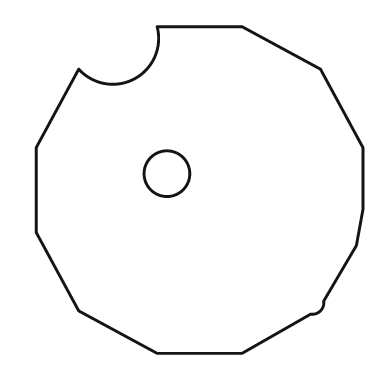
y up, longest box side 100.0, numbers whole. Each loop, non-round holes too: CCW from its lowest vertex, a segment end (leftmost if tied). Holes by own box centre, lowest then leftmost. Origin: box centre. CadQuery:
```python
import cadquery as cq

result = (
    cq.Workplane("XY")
    .moveTo(-13.0, -50.0)
    .lineTo(13.0, -50.0)
    .lineTo(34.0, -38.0)
    .threePointArc((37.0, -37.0), (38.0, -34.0))
    .lineTo(48.0, -17.0)
    .lineTo(50.0, -6.0)
    .lineTo(50.0, 13.0)
    .lineTo(37.0, 37.0)
    .lineTo(13.0, 50.0)
    .lineTo(-13.0, 50.0)
    .threePointArc((-20.0, 34.0), (-37.0, 37.0))
    .lineTo(-50.0, 13.0)
    .lineTo(-50.0, -13.0)
    .lineTo(-37.0, -37.0)
    .close()
    .moveTo(-10.0, 5.0)
    .circle(7.0)
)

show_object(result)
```